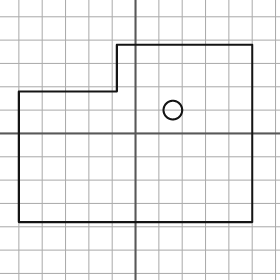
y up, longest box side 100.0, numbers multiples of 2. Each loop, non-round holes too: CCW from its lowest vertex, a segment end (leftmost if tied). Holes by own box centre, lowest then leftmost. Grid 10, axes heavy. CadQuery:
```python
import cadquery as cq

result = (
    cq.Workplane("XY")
    .moveTo(-50.0, -38.0)
    .lineTo(50.0, -38.0)
    .lineTo(50.0, 38.0)
    .lineTo(-8.0, 38.0)
    .lineTo(-8.0, 18.0)
    .lineTo(-50.0, 18.0)
    .close()
    .moveTo(16.0, 10.0)
    .circle(4.0)
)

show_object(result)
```